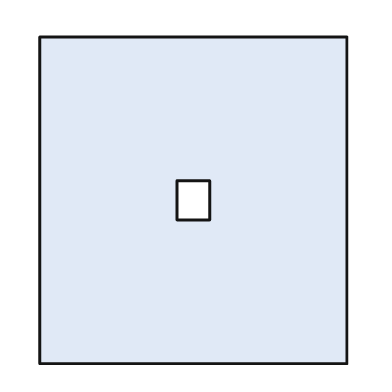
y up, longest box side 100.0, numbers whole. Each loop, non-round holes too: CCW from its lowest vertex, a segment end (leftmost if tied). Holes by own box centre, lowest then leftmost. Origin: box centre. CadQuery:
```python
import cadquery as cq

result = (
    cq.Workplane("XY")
    .moveTo(-47.0, -50.0)
    .lineTo(47.0, -50.0)
    .lineTo(47.0, 50.0)
    .lineTo(-47.0, 50.0)
    .close()
    .moveTo(-5.0, -6.0)
    .lineTo(5.0, -6.0)
    .lineTo(5.0, 6.0)
    .lineTo(-5.0, 6.0)
    .close()
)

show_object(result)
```